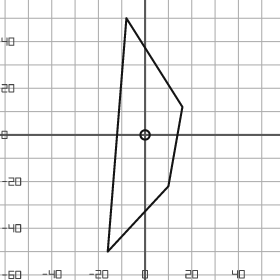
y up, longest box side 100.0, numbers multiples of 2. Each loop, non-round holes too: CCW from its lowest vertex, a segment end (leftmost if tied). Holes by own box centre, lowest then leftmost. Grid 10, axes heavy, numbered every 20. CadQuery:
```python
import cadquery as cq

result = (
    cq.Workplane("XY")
    .moveTo(-16.0, -50.0)
    .lineTo(10.0, -22.0)
    .lineTo(16.0, 12.0)
    .lineTo(-8.0, 50.0)
    .close()
    .moveTo(0.0, 0.0)
    .circle(2.0)
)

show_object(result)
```